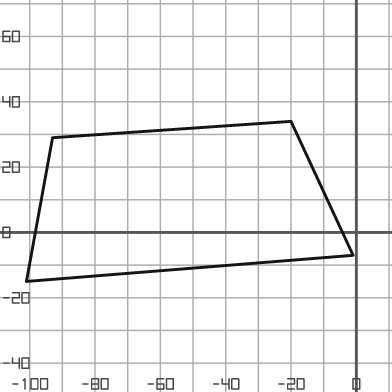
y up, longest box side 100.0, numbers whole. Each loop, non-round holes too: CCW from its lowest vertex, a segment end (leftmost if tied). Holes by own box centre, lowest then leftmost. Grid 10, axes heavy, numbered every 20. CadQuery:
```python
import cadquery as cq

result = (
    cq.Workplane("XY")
    .moveTo(-101.0, -15.0)
    .lineTo(-1.0, -7.0)
    .lineTo(-20.0, 34.0)
    .lineTo(-93.0, 29.0)
    .close()
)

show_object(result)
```